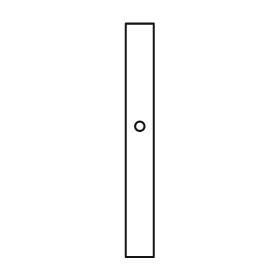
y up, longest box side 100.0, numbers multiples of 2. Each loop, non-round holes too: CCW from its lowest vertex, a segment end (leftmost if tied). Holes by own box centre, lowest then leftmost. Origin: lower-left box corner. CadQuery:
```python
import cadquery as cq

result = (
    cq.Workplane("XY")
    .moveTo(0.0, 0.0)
    .lineTo(12.0, 0.0)
    .lineTo(12.0, 100.0)
    .lineTo(0.0, 100.0)
    .close()
    .moveTo(6.0, 56.0)
    .circle(2.0)
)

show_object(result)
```